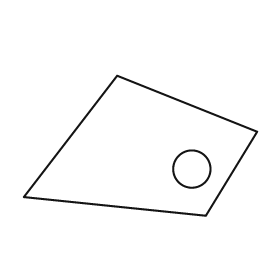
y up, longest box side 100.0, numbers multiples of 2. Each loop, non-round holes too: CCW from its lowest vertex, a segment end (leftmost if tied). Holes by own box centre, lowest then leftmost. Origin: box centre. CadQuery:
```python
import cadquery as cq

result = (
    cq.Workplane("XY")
    .moveTo(28.0, -30.0)
    .lineTo(50.0, 6.0)
    .lineTo(-10.0, 30.0)
    .lineTo(-50.0, -22.0)
    .close()
    .moveTo(22.0, -10.0)
    .circle(8.0)
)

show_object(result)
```